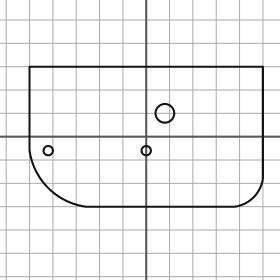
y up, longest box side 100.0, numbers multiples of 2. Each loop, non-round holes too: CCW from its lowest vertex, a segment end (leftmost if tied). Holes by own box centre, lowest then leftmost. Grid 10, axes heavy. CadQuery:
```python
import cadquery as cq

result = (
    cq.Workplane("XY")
    .moveTo(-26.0, -30.0)
    .lineTo(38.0, -30.0)
    .threePointArc((46.0, -26.0), (50.0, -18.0))
    .lineTo(50.0, 30.0)
    .lineTo(-50.0, 30.0)
    .lineTo(-50.0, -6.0)
    .threePointArc((-42.0, -22.0), (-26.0, -30.0))
    .close()
    .moveTo(-42.0, -6.0)
    .circle(2.0)
    .moveTo(0.0, -6.0)
    .circle(2.0)
    .moveTo(8.0, 10.0)
    .circle(4.0)
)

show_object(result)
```